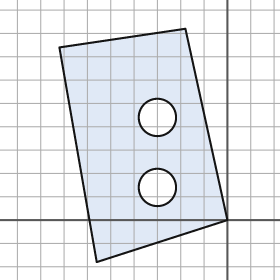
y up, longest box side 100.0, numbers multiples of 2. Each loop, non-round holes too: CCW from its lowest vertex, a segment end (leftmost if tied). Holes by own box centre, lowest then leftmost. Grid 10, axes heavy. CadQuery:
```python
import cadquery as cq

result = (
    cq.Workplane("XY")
    .moveTo(-56.0, -18.0)
    .lineTo(0.0, 0.0)
    .lineTo(-18.0, 82.0)
    .lineTo(-72.0, 74.0)
    .close()
    .moveTo(-30.0, 14.0)
    .circle(8.0)
    .moveTo(-30.0, 44.0)
    .circle(8.0)
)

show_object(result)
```